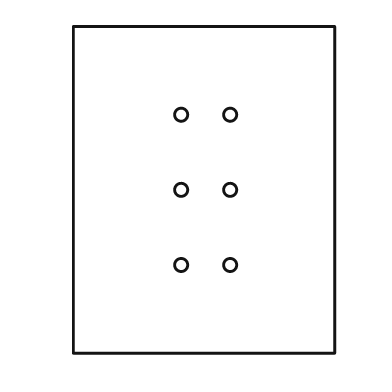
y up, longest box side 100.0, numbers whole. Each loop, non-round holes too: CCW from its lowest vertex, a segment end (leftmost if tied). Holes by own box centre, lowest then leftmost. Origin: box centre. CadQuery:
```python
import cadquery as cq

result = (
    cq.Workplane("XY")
    .moveTo(-40.0, -50.0)
    .lineTo(40.0, -50.0)
    .lineTo(40.0, 50.0)
    .lineTo(-40.0, 50.0)
    .close()
    .moveTo(-7.0, -23.0)
    .circle(2.0)
    .moveTo(8.0, -23.0)
    .circle(2.0)
    .moveTo(-7.0, 0.0)
    .circle(2.0)
    .moveTo(8.0, 0.0)
    .circle(2.0)
    .moveTo(-7.0, 23.0)
    .circle(2.0)
    .moveTo(8.0, 23.0)
    .circle(2.0)
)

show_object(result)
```